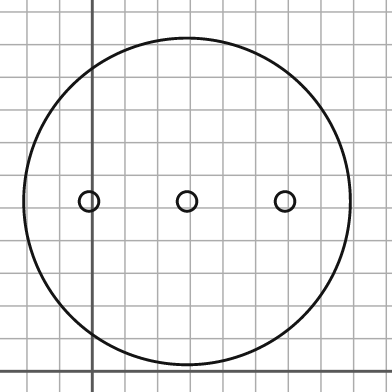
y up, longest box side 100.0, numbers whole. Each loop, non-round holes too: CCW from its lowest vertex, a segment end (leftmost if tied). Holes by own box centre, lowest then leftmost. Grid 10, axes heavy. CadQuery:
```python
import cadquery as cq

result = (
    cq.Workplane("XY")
    .moveTo(29.0, 52.0)
    .circle(50.0)
    .moveTo(-1.0, 52.0)
    .circle(3.0)
    .moveTo(29.0, 52.0)
    .circle(3.0)
    .moveTo(59.0, 52.0)
    .circle(3.0)
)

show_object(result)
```